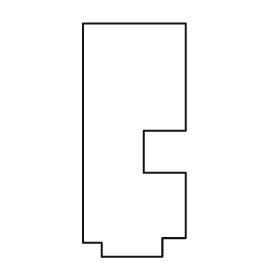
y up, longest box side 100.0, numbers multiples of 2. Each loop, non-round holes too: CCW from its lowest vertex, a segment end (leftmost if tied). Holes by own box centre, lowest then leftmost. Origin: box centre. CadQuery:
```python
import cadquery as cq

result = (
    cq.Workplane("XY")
    .moveTo(-14.0, -50.0)
    .lineTo(12.0, -50.0)
    .lineTo(12.0, -42.0)
    .lineTo(22.0, -42.0)
    .lineTo(22.0, -14.0)
    .lineTo(4.0, -14.0)
    .lineTo(4.0, 4.0)
    .lineTo(22.0, 4.0)
    .lineTo(22.0, 50.0)
    .lineTo(-22.0, 50.0)
    .lineTo(-22.0, -44.0)
    .lineTo(-14.0, -44.0)
    .close()
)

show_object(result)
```